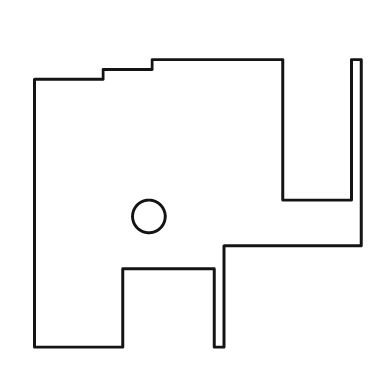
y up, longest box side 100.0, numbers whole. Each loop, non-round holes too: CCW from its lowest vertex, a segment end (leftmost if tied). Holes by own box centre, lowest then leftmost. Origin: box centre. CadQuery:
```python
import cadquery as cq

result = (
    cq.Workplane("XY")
    .moveTo(-50.0, -44.0)
    .lineTo(-23.0, -44.0)
    .lineTo(-23.0, -20.0)
    .lineTo(5.0, -20.0)
    .lineTo(5.0, -44.0)
    .lineTo(8.0, -44.0)
    .lineTo(8.0, -13.0)
    .lineTo(50.0, -13.0)
    .lineTo(50.0, 44.0)
    .lineTo(47.0, 44.0)
    .lineTo(47.0, 1.0)
    .lineTo(26.0, 1.0)
    .lineTo(26.0, 44.0)
    .lineTo(-14.0, 44.0)
    .lineTo(-14.0, 41.0)
    .lineTo(-29.0, 41.0)
    .lineTo(-29.0, 38.0)
    .lineTo(-50.0, 38.0)
    .close()
    .moveTo(-15.0, -4.0)
    .circle(5.0)
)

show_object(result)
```